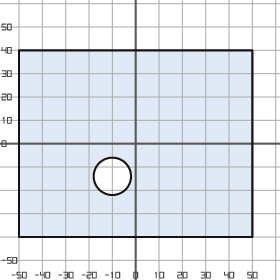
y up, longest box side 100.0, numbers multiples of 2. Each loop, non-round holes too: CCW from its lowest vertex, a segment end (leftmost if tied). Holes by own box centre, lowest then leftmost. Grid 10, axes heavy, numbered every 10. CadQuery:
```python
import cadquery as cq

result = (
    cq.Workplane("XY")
    .moveTo(-50.0, -40.0)
    .lineTo(50.0, -40.0)
    .lineTo(50.0, 40.0)
    .lineTo(-50.0, 40.0)
    .close()
    .moveTo(-10.0, -14.0)
    .circle(8.0)
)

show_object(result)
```